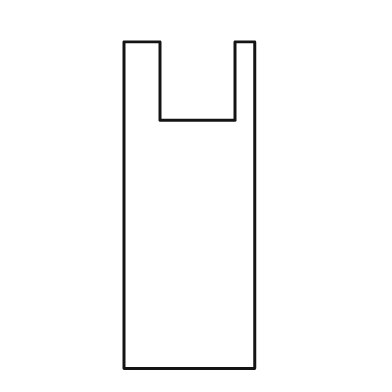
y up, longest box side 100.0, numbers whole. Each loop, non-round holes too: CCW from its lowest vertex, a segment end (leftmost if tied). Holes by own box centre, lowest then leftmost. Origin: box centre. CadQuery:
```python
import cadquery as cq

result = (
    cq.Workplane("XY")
    .moveTo(-20.0, -50.0)
    .lineTo(20.0, -50.0)
    .lineTo(20.0, 50.0)
    .lineTo(14.0, 50.0)
    .lineTo(14.0, 26.0)
    .lineTo(-9.0, 26.0)
    .lineTo(-9.0, 50.0)
    .lineTo(-20.0, 50.0)
    .close()
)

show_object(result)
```